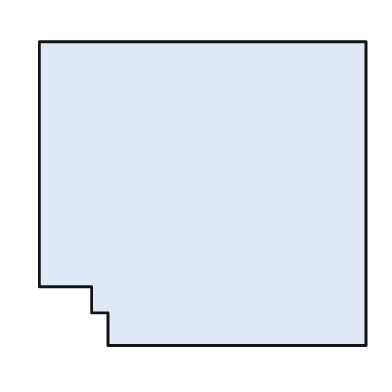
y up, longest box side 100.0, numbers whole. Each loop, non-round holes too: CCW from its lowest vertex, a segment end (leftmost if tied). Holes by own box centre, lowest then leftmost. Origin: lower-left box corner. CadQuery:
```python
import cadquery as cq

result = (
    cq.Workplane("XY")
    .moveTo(21.0, 0.0)
    .lineTo(100.0, 0.0)
    .lineTo(100.0, 93.0)
    .lineTo(0.0, 93.0)
    .lineTo(0.0, 18.0)
    .lineTo(16.0, 18.0)
    .lineTo(16.0, 10.0)
    .lineTo(21.0, 10.0)
    .close()
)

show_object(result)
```